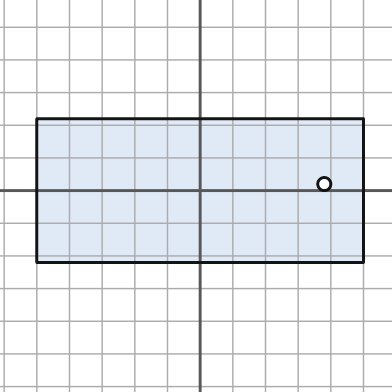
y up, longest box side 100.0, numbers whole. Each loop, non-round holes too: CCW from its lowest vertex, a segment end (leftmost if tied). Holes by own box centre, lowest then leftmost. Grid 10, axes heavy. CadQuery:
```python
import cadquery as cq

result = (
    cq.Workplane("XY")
    .moveTo(-50.0, -22.0)
    .lineTo(50.0, -22.0)
    .lineTo(50.0, 22.0)
    .lineTo(-50.0, 22.0)
    .close()
    .moveTo(38.0, 2.0)
    .circle(2.0)
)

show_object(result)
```